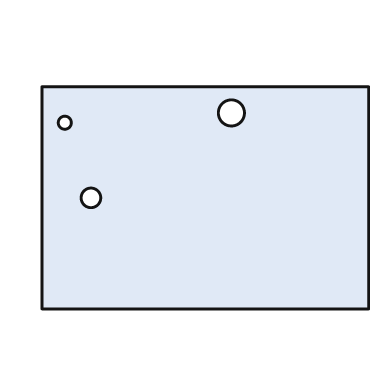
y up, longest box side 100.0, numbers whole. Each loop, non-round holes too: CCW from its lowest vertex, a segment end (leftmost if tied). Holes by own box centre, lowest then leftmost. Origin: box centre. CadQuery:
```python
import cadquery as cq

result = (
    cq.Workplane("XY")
    .moveTo(-50.0, -34.0)
    .lineTo(50.0, -34.0)
    .lineTo(50.0, 34.0)
    .lineTo(-50.0, 34.0)
    .close()
    .moveTo(-35.0, 0.0)
    .circle(3.0)
    .moveTo(-43.0, 23.0)
    .circle(2.0)
    .moveTo(8.0, 26.0)
    .circle(4.0)
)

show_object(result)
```